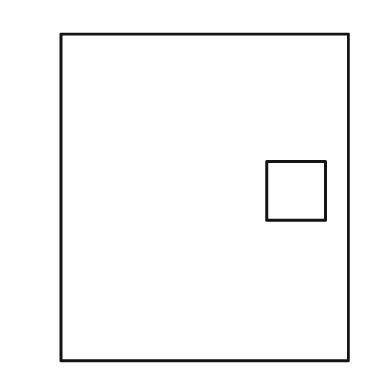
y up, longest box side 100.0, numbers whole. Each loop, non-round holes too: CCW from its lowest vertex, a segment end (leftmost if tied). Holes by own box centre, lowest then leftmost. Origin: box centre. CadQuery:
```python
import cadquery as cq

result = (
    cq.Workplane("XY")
    .moveTo(-44.0, -50.0)
    .lineTo(44.0, -50.0)
    .lineTo(44.0, 50.0)
    .lineTo(-44.0, 50.0)
    .close()
    .moveTo(19.0, -7.0)
    .lineTo(37.0, -7.0)
    .lineTo(37.0, 11.0)
    .lineTo(19.0, 11.0)
    .close()
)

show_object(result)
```